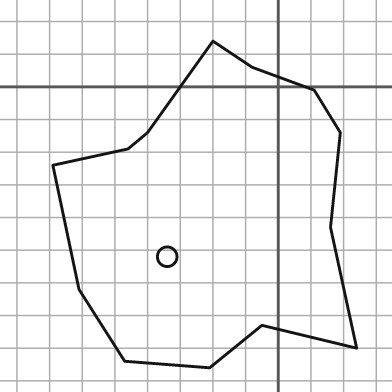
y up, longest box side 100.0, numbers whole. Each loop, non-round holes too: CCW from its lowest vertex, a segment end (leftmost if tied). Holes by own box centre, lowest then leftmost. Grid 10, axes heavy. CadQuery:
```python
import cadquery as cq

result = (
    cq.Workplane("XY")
    .moveTo(-21.0, -86.0)
    .lineTo(-5.0, -73.0)
    .lineTo(24.0, -80.0)
    .lineTo(16.0, -43.0)
    .lineTo(19.0, -14.0)
    .lineTo(11.0, -1.0)
    .lineTo(-8.0, 6.0)
    .lineTo(-20.0, 14.0)
    .lineTo(-40.0, -14.0)
    .lineTo(-46.0, -19.0)
    .lineTo(-69.0, -24.0)
    .lineTo(-61.0, -62.0)
    .lineTo(-47.0, -84.0)
    .close()
    .moveTo(-34.0, -52.0)
    .circle(3.0)
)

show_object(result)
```